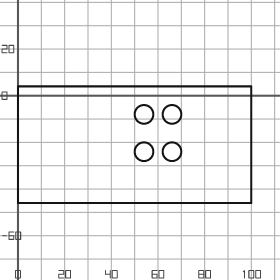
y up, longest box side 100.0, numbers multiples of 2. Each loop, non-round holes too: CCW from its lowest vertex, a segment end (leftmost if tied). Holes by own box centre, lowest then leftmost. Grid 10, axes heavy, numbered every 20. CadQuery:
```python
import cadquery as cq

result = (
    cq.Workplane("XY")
    .moveTo(0.0, -46.0)
    .lineTo(100.0, -46.0)
    .lineTo(100.0, 4.0)
    .lineTo(0.0, 4.0)
    .close()
    .moveTo(54.0, -24.0)
    .circle(4.0)
    .moveTo(66.0, -24.0)
    .circle(4.0)
    .moveTo(54.0, -8.0)
    .circle(4.0)
    .moveTo(66.0, -8.0)
    .circle(4.0)
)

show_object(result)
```